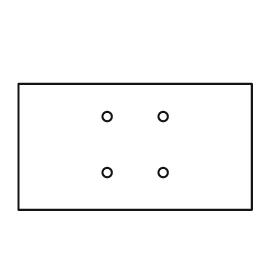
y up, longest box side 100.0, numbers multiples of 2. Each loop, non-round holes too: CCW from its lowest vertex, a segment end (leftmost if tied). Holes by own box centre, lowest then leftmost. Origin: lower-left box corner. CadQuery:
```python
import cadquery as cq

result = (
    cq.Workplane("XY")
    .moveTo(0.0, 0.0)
    .lineTo(100.0, 0.0)
    .lineTo(100.0, 54.0)
    .lineTo(0.0, 54.0)
    .close()
    .moveTo(38.0, 16.0)
    .circle(2.0)
    .moveTo(62.0, 16.0)
    .circle(2.0)
    .moveTo(38.0, 40.0)
    .circle(2.0)
    .moveTo(62.0, 40.0)
    .circle(2.0)
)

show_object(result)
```